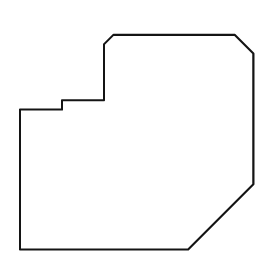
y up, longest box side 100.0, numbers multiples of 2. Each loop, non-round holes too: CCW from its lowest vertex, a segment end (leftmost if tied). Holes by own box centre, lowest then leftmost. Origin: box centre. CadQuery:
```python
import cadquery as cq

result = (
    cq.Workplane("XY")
    .moveTo(-50.0, -46.0)
    .lineTo(22.0, -46.0)
    .lineTo(50.0, -18.0)
    .lineTo(50.0, 38.0)
    .lineTo(42.0, 46.0)
    .lineTo(-10.0, 46.0)
    .lineTo(-14.0, 42.0)
    .lineTo(-14.0, 18.0)
    .lineTo(-32.0, 18.0)
    .lineTo(-32.0, 14.0)
    .lineTo(-50.0, 14.0)
    .close()
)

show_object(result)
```